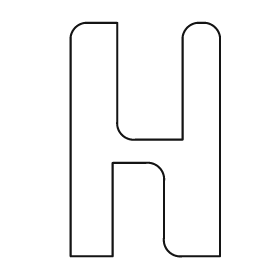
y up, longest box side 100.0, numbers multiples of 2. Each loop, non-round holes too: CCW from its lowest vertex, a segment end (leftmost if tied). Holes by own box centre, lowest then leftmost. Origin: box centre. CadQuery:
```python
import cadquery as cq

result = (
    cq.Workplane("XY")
    .moveTo(-32.0, -50.0)
    .lineTo(-14.0, -50.0)
    .lineTo(-14.0, -10.0)
    .lineTo(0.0, -10.0)
    .threePointArc((6.0, -12.0), (8.0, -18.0))
    .lineTo(8.0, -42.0)
    .threePointArc((10.0, -48.0), (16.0, -50.0))
    .lineTo(32.0, -50.0)
    .lineTo(32.0, 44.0)
    .threePointArc((30.0, 48.0), (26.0, 50.0))
    .lineTo(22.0, 50.0)
    .threePointArc((18.0, 48.0), (16.0, 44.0))
    .lineTo(16.0, 0.0)
    .lineTo(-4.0, 0.0)
    .threePointArc((-10.0, 2.0), (-12.0, 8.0))
    .lineTo(-12.0, 50.0)
    .lineTo(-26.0, 50.0)
    .threePointArc((-30.0, 48.0), (-32.0, 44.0))
    .close()
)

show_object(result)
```